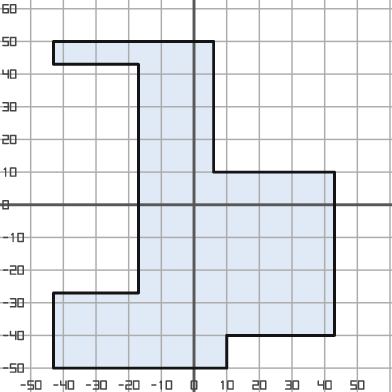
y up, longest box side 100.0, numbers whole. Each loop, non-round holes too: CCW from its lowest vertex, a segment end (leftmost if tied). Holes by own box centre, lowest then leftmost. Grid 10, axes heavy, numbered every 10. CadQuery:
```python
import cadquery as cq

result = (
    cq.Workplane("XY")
    .moveTo(-43.0, -50.0)
    .lineTo(10.0, -50.0)
    .lineTo(10.0, -40.0)
    .lineTo(43.0, -40.0)
    .lineTo(43.0, 10.0)
    .lineTo(6.0, 10.0)
    .lineTo(6.0, 50.0)
    .lineTo(-43.0, 50.0)
    .lineTo(-43.0, 43.0)
    .lineTo(-17.0, 43.0)
    .lineTo(-17.0, -27.0)
    .lineTo(-43.0, -27.0)
    .close()
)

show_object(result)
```